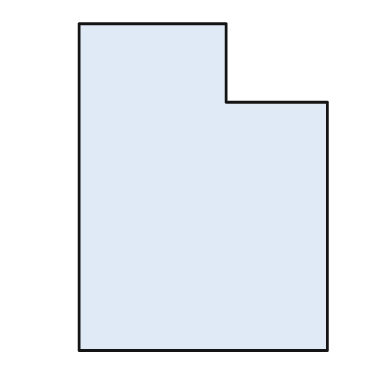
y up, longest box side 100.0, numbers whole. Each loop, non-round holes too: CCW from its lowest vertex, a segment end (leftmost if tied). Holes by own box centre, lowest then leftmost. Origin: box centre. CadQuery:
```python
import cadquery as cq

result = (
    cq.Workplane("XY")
    .moveTo(-38.0, -50.0)
    .lineTo(38.0, -50.0)
    .lineTo(38.0, 26.0)
    .lineTo(7.0, 26.0)
    .lineTo(7.0, 50.0)
    .lineTo(-38.0, 50.0)
    .close()
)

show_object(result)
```